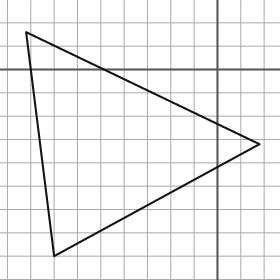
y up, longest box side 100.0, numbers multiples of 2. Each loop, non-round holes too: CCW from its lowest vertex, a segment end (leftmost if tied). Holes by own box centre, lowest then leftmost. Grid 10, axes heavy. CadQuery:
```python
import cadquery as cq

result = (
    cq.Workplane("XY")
    .moveTo(-70.0, -80.0)
    .lineTo(18.0, -32.0)
    .lineTo(-82.0, 16.0)
    .close()
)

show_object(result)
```